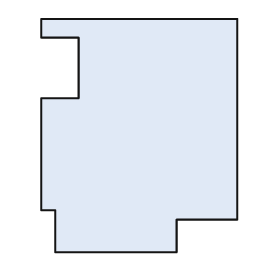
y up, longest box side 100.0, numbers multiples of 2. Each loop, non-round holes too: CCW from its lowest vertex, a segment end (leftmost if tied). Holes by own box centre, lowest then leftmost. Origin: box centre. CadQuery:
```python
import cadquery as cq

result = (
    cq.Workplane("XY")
    .moveTo(-36.0, -50.0)
    .lineTo(16.0, -50.0)
    .lineTo(16.0, -36.0)
    .lineTo(42.0, -36.0)
    .lineTo(42.0, 50.0)
    .lineTo(-42.0, 50.0)
    .lineTo(-42.0, 42.0)
    .lineTo(-26.0, 42.0)
    .lineTo(-26.0, 16.0)
    .lineTo(-42.0, 16.0)
    .lineTo(-42.0, -32.0)
    .lineTo(-36.0, -32.0)
    .close()
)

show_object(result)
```